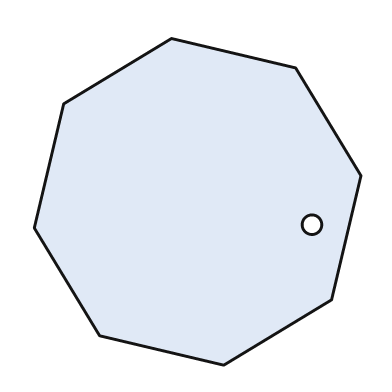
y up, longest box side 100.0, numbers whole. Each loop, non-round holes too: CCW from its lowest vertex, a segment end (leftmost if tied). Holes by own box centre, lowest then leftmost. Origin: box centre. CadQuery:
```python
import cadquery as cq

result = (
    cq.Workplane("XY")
    .moveTo(8.0, -50.0)
    .lineTo(41.0, -30.0)
    .lineTo(50.0, 8.0)
    .lineTo(30.0, 41.0)
    .lineTo(-8.0, 50.0)
    .lineTo(-41.0, 30.0)
    .lineTo(-50.0, -8.0)
    .lineTo(-30.0, -41.0)
    .close()
    .moveTo(35.0, -7.0)
    .circle(3.0)
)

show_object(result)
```